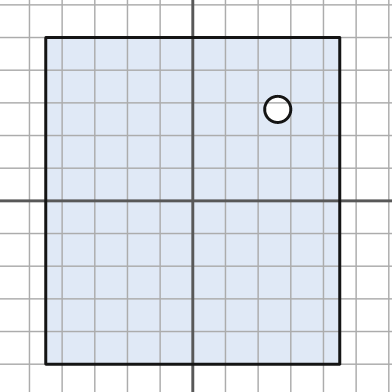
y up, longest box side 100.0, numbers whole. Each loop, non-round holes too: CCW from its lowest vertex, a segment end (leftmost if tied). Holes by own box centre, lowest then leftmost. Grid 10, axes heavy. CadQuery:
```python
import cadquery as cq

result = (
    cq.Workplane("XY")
    .moveTo(-45.0, -50.0)
    .lineTo(45.0, -50.0)
    .lineTo(45.0, 50.0)
    .lineTo(-45.0, 50.0)
    .close()
    .moveTo(26.0, 28.0)
    .circle(4.0)
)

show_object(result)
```